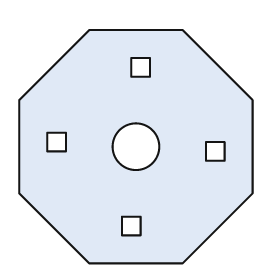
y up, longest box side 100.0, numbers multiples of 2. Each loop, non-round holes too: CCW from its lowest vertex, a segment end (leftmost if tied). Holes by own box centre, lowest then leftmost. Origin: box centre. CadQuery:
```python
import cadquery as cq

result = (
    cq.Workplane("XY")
    .moveTo(-20.0, -50.0)
    .lineTo(20.0, -50.0)
    .lineTo(50.0, -20.0)
    .lineTo(50.0, 20.0)
    .lineTo(20.0, 50.0)
    .lineTo(-20.0, 50.0)
    .lineTo(-50.0, 20.0)
    .lineTo(-50.0, -20.0)
    .close()
    .moveTo(-6.0, -38.0)
    .lineTo(2.0, -38.0)
    .lineTo(2.0, -30.0)
    .lineTo(-6.0, -30.0)
    .close()
    .moveTo(30.0, -6.0)
    .lineTo(38.0, -6.0)
    .lineTo(38.0, 2.0)
    .lineTo(30.0, 2.0)
    .close()
    .moveTo(0.0, 0.0)
    .circle(10.0)
    .moveTo(-38.0, -2.0)
    .lineTo(-30.0, -2.0)
    .lineTo(-30.0, 6.0)
    .lineTo(-38.0, 6.0)
    .close()
    .moveTo(-2.0, 30.0)
    .lineTo(6.0, 30.0)
    .lineTo(6.0, 38.0)
    .lineTo(-2.0, 38.0)
    .close()
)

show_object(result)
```